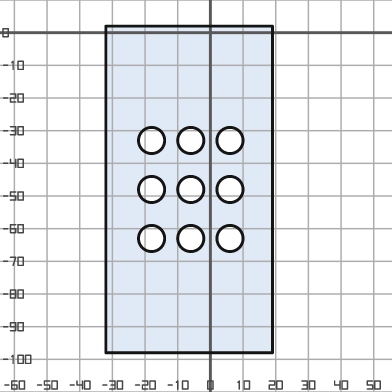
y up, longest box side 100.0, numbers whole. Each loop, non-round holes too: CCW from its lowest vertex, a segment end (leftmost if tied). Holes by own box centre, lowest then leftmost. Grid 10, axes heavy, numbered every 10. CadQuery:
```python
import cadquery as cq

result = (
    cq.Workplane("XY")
    .moveTo(-32.0, -98.0)
    .lineTo(19.0, -98.0)
    .lineTo(19.0, 2.0)
    .lineTo(-32.0, 2.0)
    .close()
    .moveTo(-18.0, -63.0)
    .circle(4.0)
    .moveTo(-6.0, -63.0)
    .circle(4.0)
    .moveTo(6.0, -63.0)
    .circle(4.0)
    .moveTo(-18.0, -48.0)
    .circle(4.0)
    .moveTo(-6.0, -48.0)
    .circle(4.0)
    .moveTo(6.0, -48.0)
    .circle(4.0)
    .moveTo(-18.0, -33.0)
    .circle(4.0)
    .moveTo(-6.0, -33.0)
    .circle(4.0)
    .moveTo(6.0, -33.0)
    .circle(4.0)
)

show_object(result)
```